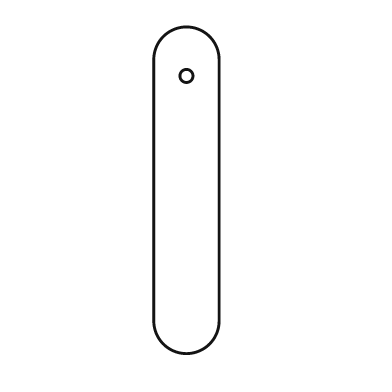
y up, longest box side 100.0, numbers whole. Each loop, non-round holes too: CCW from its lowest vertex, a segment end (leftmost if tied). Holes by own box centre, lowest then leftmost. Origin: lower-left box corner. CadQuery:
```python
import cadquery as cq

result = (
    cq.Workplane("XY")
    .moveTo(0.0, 10.0)
    .threePointArc((10.0, 0.0), (20.0, 10.0))
    .lineTo(20.0, 90.0)
    .threePointArc((10.0, 100.0), (0.0, 90.0))
    .close()
    .moveTo(10.0, 85.0)
    .circle(2.0)
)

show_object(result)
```